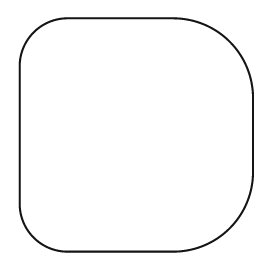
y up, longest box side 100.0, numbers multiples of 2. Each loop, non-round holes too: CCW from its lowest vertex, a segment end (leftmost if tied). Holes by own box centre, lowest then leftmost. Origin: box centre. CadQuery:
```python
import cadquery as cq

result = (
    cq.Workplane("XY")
    .moveTo(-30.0, -50.0)
    .lineTo(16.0, -50.0)
    .threePointArc((40.0, -40.0), (50.0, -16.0))
    .lineTo(50.0, 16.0)
    .threePointArc((40.0, 40.0), (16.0, 50.0))
    .lineTo(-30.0, 50.0)
    .threePointArc((-44.0, 44.0), (-50.0, 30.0))
    .lineTo(-50.0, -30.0)
    .threePointArc((-44.0, -44.0), (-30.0, -50.0))
    .close()
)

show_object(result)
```